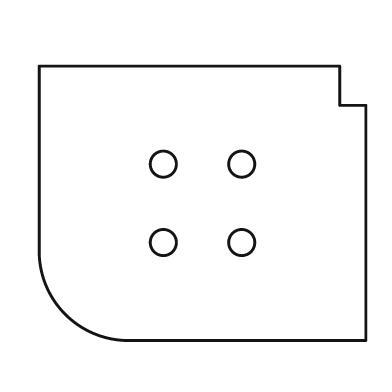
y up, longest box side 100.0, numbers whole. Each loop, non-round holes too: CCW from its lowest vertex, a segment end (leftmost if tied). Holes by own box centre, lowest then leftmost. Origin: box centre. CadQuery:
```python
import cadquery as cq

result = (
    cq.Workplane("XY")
    .moveTo(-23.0, -42.0)
    .lineTo(50.0, -42.0)
    .lineTo(50.0, 30.0)
    .lineTo(42.0, 30.0)
    .lineTo(42.0, 42.0)
    .lineTo(-50.0, 42.0)
    .lineTo(-50.0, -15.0)
    .threePointArc((-42.0, -34.0), (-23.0, -42.0))
    .close()
    .moveTo(-12.0, -12.0)
    .circle(4.0)
    .moveTo(12.0, -12.0)
    .circle(4.0)
    .moveTo(-12.0, 12.0)
    .circle(4.0)
    .moveTo(12.0, 12.0)
    .circle(4.0)
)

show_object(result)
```